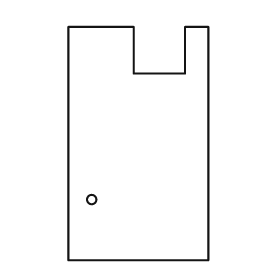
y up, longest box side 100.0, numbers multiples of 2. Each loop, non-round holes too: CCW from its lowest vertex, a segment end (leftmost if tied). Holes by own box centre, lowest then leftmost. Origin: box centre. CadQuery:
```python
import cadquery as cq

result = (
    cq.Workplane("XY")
    .moveTo(-30.0, -50.0)
    .lineTo(30.0, -50.0)
    .lineTo(30.0, 50.0)
    .lineTo(20.0, 50.0)
    .lineTo(20.0, 30.0)
    .lineTo(-2.0, 30.0)
    .lineTo(-2.0, 50.0)
    .lineTo(-30.0, 50.0)
    .close()
    .moveTo(-20.0, -24.0)
    .circle(2.0)
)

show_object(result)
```